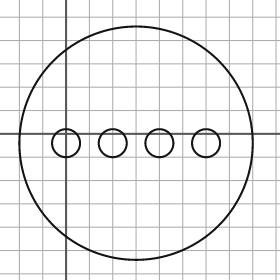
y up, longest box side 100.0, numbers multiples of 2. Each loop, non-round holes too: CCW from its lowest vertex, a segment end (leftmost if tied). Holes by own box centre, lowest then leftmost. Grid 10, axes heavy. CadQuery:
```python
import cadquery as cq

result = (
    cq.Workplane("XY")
    .moveTo(30.0, -4.0)
    .circle(50.0)
    .moveTo(0.0, -4.0)
    .circle(6.0)
    .moveTo(20.0, -4.0)
    .circle(6.0)
    .moveTo(40.0, -4.0)
    .circle(6.0)
    .moveTo(60.0, -4.0)
    .circle(6.0)
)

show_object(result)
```